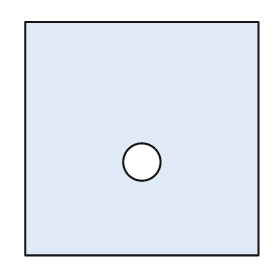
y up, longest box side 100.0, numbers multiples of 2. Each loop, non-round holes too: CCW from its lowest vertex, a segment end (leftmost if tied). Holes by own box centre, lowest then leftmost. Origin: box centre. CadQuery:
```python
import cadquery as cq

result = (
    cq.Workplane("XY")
    .moveTo(-50.0, -50.0)
    .lineTo(50.0, -50.0)
    .lineTo(50.0, 50.0)
    .lineTo(-50.0, 50.0)
    .close()
    .moveTo(0.0, -10.0)
    .circle(8.0)
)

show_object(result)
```